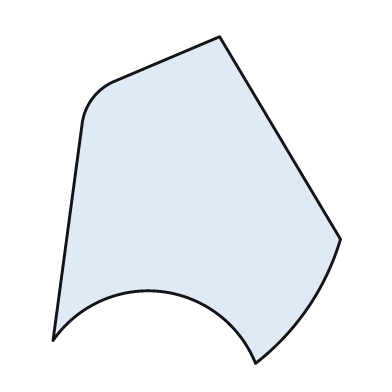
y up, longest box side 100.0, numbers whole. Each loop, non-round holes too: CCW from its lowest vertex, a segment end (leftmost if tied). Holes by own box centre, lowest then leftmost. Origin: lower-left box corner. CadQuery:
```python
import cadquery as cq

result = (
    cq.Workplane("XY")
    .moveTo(62.0, 0.0)
    .threePointArc((78.0, 17.0), (88.0, 38.0))
    .lineTo(51.0, 100.0)
    .lineTo(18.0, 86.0)
    .threePointArc((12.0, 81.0), (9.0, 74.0))
    .lineTo(0.0, 7.0)
    .threePointArc((33.0, 22.0), (62.0, 0.0))
    .close()
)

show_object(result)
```